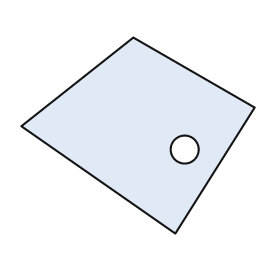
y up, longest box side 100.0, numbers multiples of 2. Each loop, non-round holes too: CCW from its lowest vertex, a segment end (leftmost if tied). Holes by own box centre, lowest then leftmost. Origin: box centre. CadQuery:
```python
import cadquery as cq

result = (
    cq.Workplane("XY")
    .moveTo(16.0, -42.0)
    .lineTo(50.0, 12.0)
    .lineTo(-2.0, 42.0)
    .lineTo(-50.0, 4.0)
    .close()
    .moveTo(20.0, -6.0)
    .circle(6.0)
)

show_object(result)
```